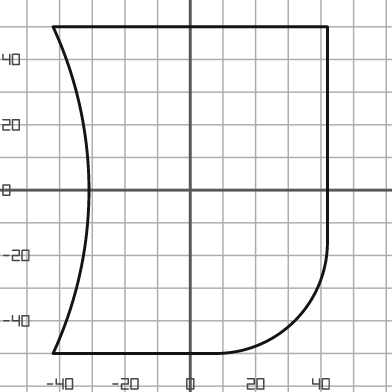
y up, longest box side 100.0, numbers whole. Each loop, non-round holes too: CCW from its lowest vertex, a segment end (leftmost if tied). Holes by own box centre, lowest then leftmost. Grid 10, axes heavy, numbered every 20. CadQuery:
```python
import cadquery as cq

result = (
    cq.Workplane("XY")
    .moveTo(-42.0, -50.0)
    .lineTo(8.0, -50.0)
    .threePointArc((32.0, -40.0), (42.0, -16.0))
    .lineTo(42.0, 50.0)
    .lineTo(-42.0, 50.0)
    .threePointArc((-31.0, 0.0), (-42.0, -50.0))
    .close()
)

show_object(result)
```